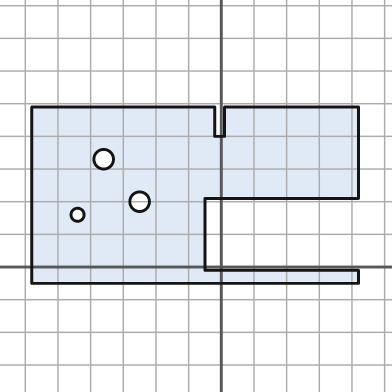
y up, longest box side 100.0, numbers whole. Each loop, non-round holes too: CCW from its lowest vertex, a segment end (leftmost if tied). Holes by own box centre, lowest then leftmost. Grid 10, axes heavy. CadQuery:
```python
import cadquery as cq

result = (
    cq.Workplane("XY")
    .moveTo(-58.0, -5.0)
    .lineTo(42.0, -5.0)
    .lineTo(42.0, -1.0)
    .lineTo(-5.0, -1.0)
    .lineTo(-5.0, 21.0)
    .lineTo(42.0, 21.0)
    .lineTo(42.0, 49.0)
    .lineTo(1.0, 49.0)
    .lineTo(1.0, 40.0)
    .lineTo(-2.0, 40.0)
    .lineTo(-2.0, 49.0)
    .lineTo(-58.0, 49.0)
    .close()
    .moveTo(-44.0, 16.0)
    .circle(2.0)
    .moveTo(-25.0, 20.0)
    .circle(3.0)
    .moveTo(-36.0, 33.0)
    .circle(3.0)
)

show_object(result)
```